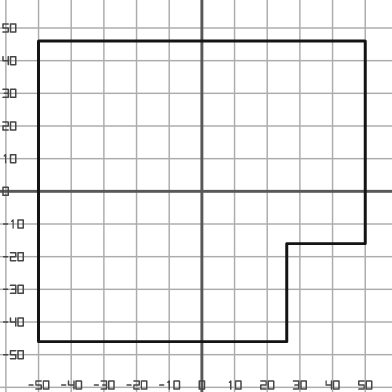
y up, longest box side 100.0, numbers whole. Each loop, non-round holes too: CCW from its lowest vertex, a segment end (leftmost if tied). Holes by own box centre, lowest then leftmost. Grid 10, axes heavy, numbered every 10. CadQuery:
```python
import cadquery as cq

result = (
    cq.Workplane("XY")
    .moveTo(-50.0, -46.0)
    .lineTo(26.0, -46.0)
    .lineTo(26.0, -16.0)
    .lineTo(50.0, -16.0)
    .lineTo(50.0, 46.0)
    .lineTo(-50.0, 46.0)
    .close()
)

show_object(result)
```